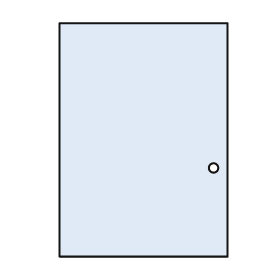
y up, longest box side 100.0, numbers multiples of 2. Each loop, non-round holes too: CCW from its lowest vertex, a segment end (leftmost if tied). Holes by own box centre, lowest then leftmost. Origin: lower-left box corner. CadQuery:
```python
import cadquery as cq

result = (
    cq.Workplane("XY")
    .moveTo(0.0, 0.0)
    .lineTo(72.0, 0.0)
    .lineTo(72.0, 100.0)
    .lineTo(0.0, 100.0)
    .close()
    .moveTo(66.0, 38.0)
    .circle(2.0)
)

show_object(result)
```